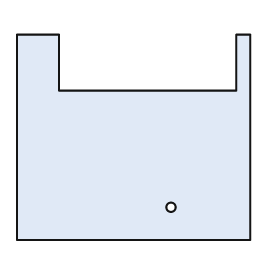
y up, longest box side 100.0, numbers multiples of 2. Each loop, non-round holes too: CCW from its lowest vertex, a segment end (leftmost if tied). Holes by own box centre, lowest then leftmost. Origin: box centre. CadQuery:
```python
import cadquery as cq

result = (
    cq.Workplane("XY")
    .moveTo(-50.0, -44.0)
    .lineTo(50.0, -44.0)
    .lineTo(50.0, 44.0)
    .lineTo(44.0, 44.0)
    .lineTo(44.0, 20.0)
    .lineTo(-32.0, 20.0)
    .lineTo(-32.0, 44.0)
    .lineTo(-50.0, 44.0)
    .close()
    .moveTo(16.0, -30.0)
    .circle(2.0)
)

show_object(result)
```